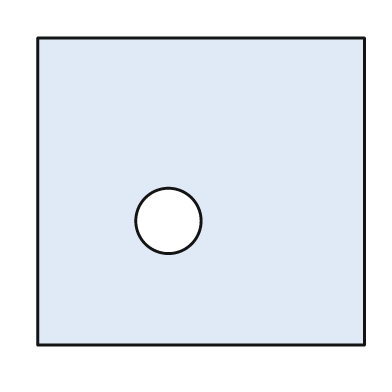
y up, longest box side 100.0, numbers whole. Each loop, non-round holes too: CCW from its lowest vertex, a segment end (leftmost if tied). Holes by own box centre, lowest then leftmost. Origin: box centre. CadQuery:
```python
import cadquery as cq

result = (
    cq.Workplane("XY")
    .moveTo(-50.0, -47.0)
    .lineTo(50.0, -47.0)
    .lineTo(50.0, 47.0)
    .lineTo(-50.0, 47.0)
    .close()
    .moveTo(-10.0, -9.0)
    .circle(10.0)
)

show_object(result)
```